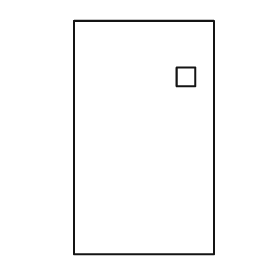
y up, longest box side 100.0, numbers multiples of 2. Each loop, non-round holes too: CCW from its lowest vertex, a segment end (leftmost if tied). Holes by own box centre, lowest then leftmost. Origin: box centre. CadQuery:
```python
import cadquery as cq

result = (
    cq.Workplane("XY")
    .moveTo(-30.0, -50.0)
    .lineTo(30.0, -50.0)
    .lineTo(30.0, 50.0)
    .lineTo(-30.0, 50.0)
    .close()
    .moveTo(14.0, 22.0)
    .lineTo(22.0, 22.0)
    .lineTo(22.0, 30.0)
    .lineTo(14.0, 30.0)
    .close()
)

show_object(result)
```